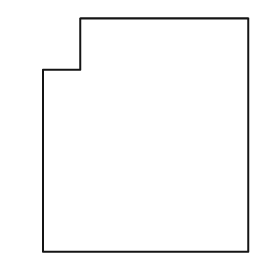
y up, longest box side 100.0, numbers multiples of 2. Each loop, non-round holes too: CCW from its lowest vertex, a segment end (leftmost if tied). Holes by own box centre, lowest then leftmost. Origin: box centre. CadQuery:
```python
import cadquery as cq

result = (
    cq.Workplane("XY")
    .moveTo(-44.0, -50.0)
    .lineTo(44.0, -50.0)
    .lineTo(44.0, 50.0)
    .lineTo(-28.0, 50.0)
    .lineTo(-28.0, 28.0)
    .lineTo(-44.0, 28.0)
    .close()
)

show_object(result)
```